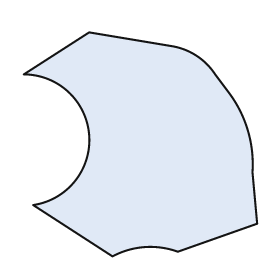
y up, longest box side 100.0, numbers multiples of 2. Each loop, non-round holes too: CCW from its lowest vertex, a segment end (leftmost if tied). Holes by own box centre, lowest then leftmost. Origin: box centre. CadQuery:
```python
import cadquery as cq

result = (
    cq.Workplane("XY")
    .moveTo(-12.0, -48.0)
    .threePointArc((2.0, -44.0), (16.0, -46.0))
    .lineTo(50.0, -34.0)
    .lineTo(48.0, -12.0)
    .threePointArc((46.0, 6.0), (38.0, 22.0))
    .lineTo(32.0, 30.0)
    .threePointArc((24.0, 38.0), (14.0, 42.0))
    .lineTo(-22.0, 48.0)
    .lineTo(-50.0, 30.0)
    .threePointArc((-22.0, 4.0), (-46.0, -26.0))
    .close()
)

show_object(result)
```